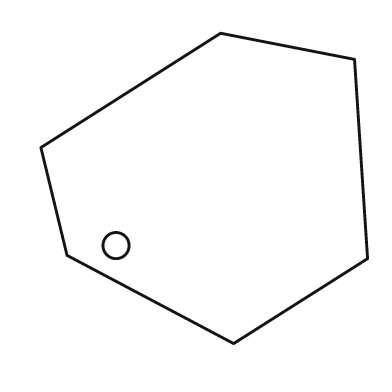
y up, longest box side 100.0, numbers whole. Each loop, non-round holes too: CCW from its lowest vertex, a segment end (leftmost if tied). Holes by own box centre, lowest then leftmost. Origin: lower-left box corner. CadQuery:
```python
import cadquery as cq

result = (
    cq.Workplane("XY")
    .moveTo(59.0, 0.0)
    .lineTo(100.0, 26.0)
    .lineTo(96.0, 87.0)
    .lineTo(55.0, 95.0)
    .lineTo(0.0, 60.0)
    .lineTo(8.0, 27.0)
    .close()
    .moveTo(23.0, 30.0)
    .circle(4.0)
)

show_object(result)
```